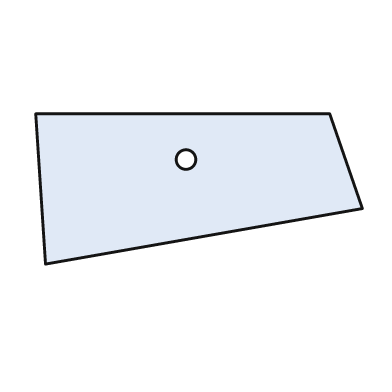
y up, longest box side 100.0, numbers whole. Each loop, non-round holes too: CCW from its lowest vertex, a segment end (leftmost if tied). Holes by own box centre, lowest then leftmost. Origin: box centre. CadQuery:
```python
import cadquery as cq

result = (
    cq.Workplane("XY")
    .moveTo(-47.0, -23.0)
    .lineTo(50.0, -6.0)
    .lineTo(40.0, 23.0)
    .lineTo(-50.0, 23.0)
    .close()
    .moveTo(-4.0, 9.0)
    .circle(3.0)
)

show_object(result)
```